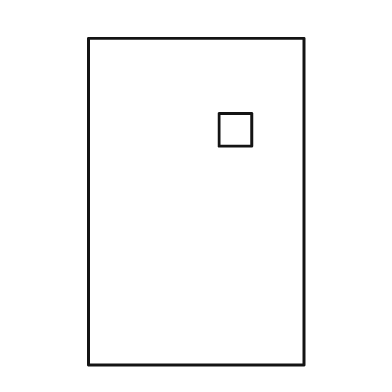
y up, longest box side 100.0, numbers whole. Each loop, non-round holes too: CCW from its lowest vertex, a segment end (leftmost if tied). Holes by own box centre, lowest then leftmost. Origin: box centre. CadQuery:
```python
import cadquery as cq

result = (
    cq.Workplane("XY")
    .moveTo(-33.0, -50.0)
    .lineTo(33.0, -50.0)
    .lineTo(33.0, 50.0)
    .lineTo(-33.0, 50.0)
    .close()
    .moveTo(7.0, 17.0)
    .lineTo(17.0, 17.0)
    .lineTo(17.0, 27.0)
    .lineTo(7.0, 27.0)
    .close()
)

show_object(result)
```